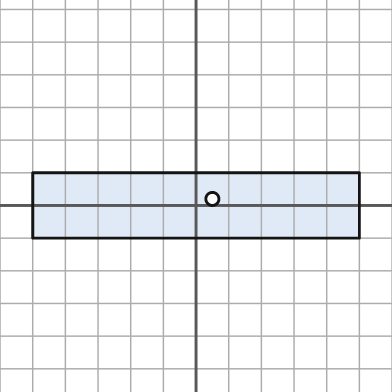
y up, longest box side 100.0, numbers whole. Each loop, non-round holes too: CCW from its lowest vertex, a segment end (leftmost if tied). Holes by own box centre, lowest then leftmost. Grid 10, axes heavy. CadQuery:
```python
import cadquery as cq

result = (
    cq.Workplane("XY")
    .moveTo(-50.0, -10.0)
    .lineTo(50.0, -10.0)
    .lineTo(50.0, 10.0)
    .lineTo(-50.0, 10.0)
    .close()
    .moveTo(5.0, 2.0)
    .circle(2.0)
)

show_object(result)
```